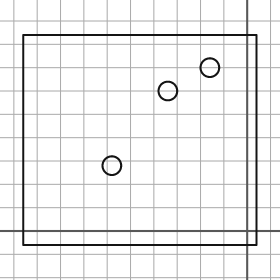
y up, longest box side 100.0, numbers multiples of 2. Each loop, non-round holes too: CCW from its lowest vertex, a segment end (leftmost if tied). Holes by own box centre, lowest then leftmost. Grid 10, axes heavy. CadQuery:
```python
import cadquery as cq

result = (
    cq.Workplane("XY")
    .moveTo(-96.0, -6.0)
    .lineTo(4.0, -6.0)
    .lineTo(4.0, 84.0)
    .lineTo(-96.0, 84.0)
    .close()
    .moveTo(-58.0, 28.0)
    .circle(4.0)
    .moveTo(-34.0, 60.0)
    .circle(4.0)
    .moveTo(-16.0, 70.0)
    .circle(4.0)
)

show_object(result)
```